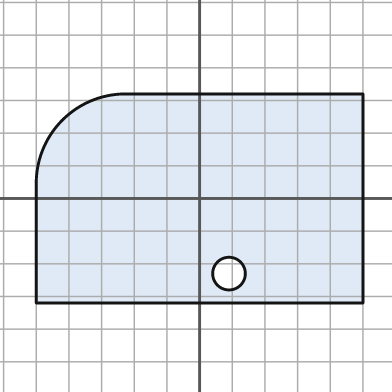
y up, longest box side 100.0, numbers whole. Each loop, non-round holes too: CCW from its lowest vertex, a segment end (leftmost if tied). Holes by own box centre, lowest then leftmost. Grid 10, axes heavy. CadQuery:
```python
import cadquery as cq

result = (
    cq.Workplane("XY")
    .moveTo(-50.0, -32.0)
    .lineTo(50.0, -32.0)
    .lineTo(50.0, 32.0)
    .lineTo(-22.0, 32.0)
    .threePointArc((-42.0, 24.0), (-50.0, 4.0))
    .close()
    .moveTo(9.0, -23.0)
    .circle(5.0)
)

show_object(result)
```